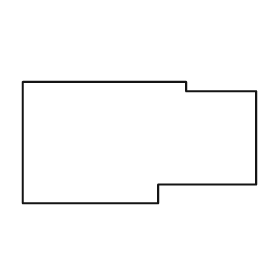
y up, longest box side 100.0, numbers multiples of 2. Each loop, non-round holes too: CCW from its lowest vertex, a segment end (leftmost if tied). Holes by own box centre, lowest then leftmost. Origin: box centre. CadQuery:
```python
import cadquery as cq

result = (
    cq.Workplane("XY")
    .moveTo(-50.0, -26.0)
    .lineTo(8.0, -26.0)
    .lineTo(8.0, -18.0)
    .lineTo(50.0, -18.0)
    .lineTo(50.0, 22.0)
    .lineTo(20.0, 22.0)
    .lineTo(20.0, 26.0)
    .lineTo(-50.0, 26.0)
    .close()
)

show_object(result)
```